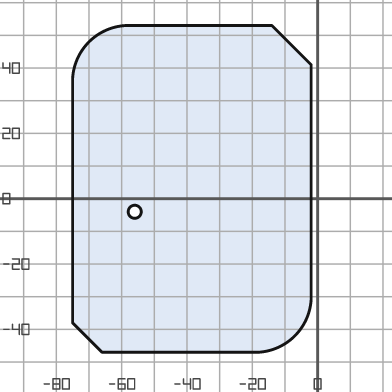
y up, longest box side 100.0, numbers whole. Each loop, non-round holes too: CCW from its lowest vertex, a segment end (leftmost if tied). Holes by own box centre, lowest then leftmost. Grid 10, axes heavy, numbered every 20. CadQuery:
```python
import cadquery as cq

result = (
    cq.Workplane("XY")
    .moveTo(-66.0, -47.0)
    .lineTo(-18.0, -47.0)
    .threePointArc((-7.0, -42.0), (-2.0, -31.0))
    .lineTo(-2.0, 41.0)
    .lineTo(-14.0, 53.0)
    .lineTo(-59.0, 53.0)
    .threePointArc((-70.0, 48.0), (-75.0, 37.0))
    .lineTo(-75.0, -38.0)
    .close()
    .moveTo(-56.0, -4.0)
    .circle(2.0)
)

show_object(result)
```